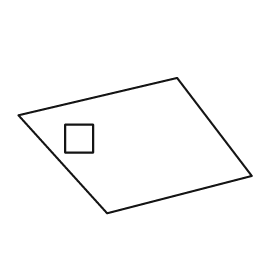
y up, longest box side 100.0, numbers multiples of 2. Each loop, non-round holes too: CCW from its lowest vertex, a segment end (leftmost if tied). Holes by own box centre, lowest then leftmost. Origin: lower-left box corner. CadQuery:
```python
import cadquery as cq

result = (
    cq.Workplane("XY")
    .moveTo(38.0, 0.0)
    .lineTo(100.0, 16.0)
    .lineTo(68.0, 58.0)
    .lineTo(0.0, 42.0)
    .close()
    .moveTo(20.0, 26.0)
    .lineTo(32.0, 26.0)
    .lineTo(32.0, 38.0)
    .lineTo(20.0, 38.0)
    .close()
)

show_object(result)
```